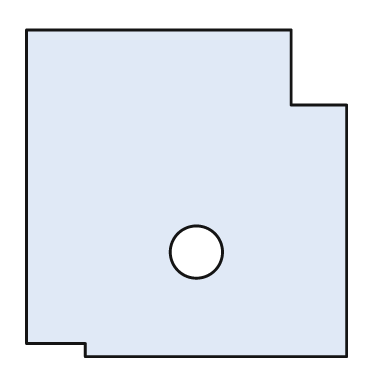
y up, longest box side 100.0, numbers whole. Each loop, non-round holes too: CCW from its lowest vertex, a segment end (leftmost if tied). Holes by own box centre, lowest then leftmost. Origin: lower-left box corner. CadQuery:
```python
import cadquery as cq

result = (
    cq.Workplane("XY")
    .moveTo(18.0, 0.0)
    .lineTo(98.0, 0.0)
    .lineTo(98.0, 77.0)
    .lineTo(81.0, 77.0)
    .lineTo(81.0, 100.0)
    .lineTo(0.0, 100.0)
    .lineTo(0.0, 4.0)
    .lineTo(18.0, 4.0)
    .close()
    .moveTo(52.0, 32.0)
    .circle(8.0)
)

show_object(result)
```